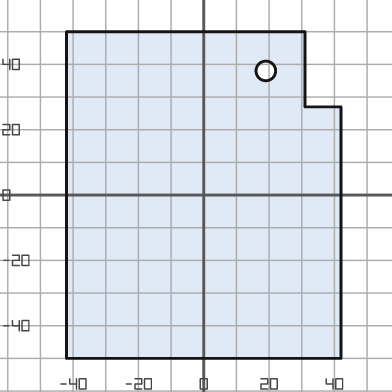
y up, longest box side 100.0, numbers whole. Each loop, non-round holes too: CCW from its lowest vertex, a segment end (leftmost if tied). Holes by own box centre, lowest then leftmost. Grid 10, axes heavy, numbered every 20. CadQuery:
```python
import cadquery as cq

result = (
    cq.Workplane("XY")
    .moveTo(-42.0, -50.0)
    .lineTo(42.0, -50.0)
    .lineTo(42.0, 27.0)
    .lineTo(31.0, 27.0)
    .lineTo(31.0, 50.0)
    .lineTo(-42.0, 50.0)
    .close()
    .moveTo(19.0, 38.0)
    .circle(3.0)
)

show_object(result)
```